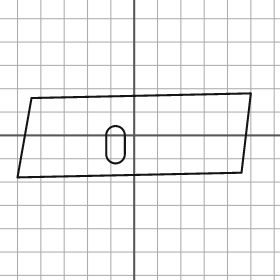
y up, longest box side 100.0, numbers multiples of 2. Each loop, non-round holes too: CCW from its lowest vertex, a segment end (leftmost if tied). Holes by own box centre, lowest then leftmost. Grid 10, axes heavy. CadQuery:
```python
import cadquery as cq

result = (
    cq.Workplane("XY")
    .moveTo(-50.0, -18.0)
    .lineTo(46.0, -16.0)
    .lineTo(50.0, 18.0)
    .lineTo(-44.0, 16.0)
    .close()
    .moveTo(-12.0, -8.0)
    .threePointArc((-8.0, -12.0), (-4.0, -8.0))
    .lineTo(-4.0, 0.0)
    .threePointArc((-8.0, 4.0), (-12.0, 0.0))
    .close()
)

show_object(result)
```